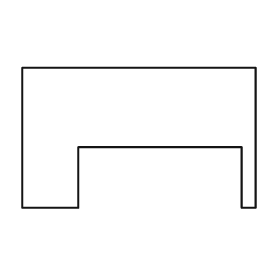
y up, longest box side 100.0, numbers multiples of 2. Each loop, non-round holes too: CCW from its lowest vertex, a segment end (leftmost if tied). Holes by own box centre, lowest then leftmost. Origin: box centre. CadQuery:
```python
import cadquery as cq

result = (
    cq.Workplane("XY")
    .moveTo(-50.0, -30.0)
    .lineTo(-26.0, -30.0)
    .lineTo(-26.0, -4.0)
    .lineTo(44.0, -4.0)
    .lineTo(44.0, -30.0)
    .lineTo(50.0, -30.0)
    .lineTo(50.0, 30.0)
    .lineTo(-50.0, 30.0)
    .close()
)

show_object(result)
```